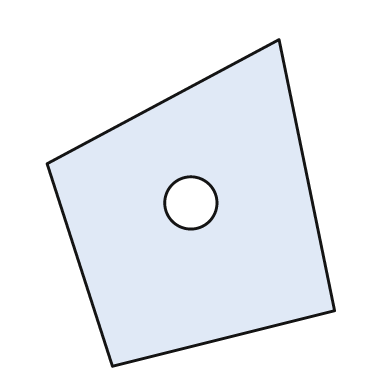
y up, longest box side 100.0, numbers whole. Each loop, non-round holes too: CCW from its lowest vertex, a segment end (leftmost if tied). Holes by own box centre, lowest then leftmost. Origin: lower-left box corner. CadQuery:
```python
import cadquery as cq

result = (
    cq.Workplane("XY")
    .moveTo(20.0, 0.0)
    .lineTo(88.0, 17.0)
    .lineTo(71.0, 100.0)
    .lineTo(0.0, 62.0)
    .close()
    .moveTo(44.0, 50.0)
    .circle(8.0)
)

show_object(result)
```